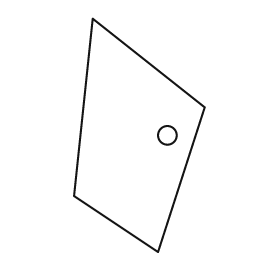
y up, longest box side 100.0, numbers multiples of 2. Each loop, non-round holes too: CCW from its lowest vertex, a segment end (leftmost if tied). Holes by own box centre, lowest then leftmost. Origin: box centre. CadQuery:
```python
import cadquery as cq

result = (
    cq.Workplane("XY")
    .moveTo(8.0, -50.0)
    .lineTo(28.0, 12.0)
    .lineTo(-20.0, 50.0)
    .lineTo(-28.0, -26.0)
    .close()
    .moveTo(12.0, 0.0)
    .circle(4.0)
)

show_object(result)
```